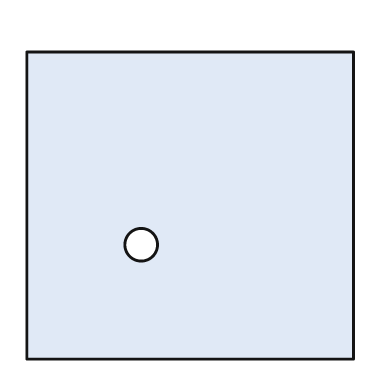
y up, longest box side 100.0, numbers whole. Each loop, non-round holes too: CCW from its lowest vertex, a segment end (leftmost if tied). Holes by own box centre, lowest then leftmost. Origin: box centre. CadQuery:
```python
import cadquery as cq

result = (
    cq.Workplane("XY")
    .moveTo(-50.0, -47.0)
    .lineTo(50.0, -47.0)
    .lineTo(50.0, 47.0)
    .lineTo(-50.0, 47.0)
    .close()
    .moveTo(-15.0, -12.0)
    .circle(5.0)
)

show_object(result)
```